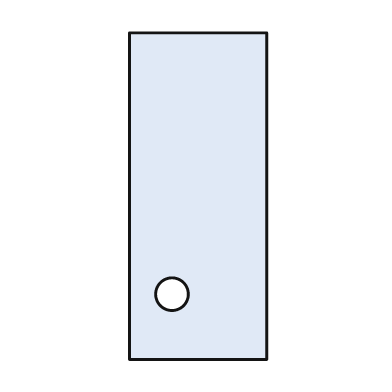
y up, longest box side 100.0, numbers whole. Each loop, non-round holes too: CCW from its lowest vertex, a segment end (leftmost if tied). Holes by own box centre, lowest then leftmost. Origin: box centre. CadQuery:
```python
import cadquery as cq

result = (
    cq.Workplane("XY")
    .moveTo(-21.0, -50.0)
    .lineTo(21.0, -50.0)
    .lineTo(21.0, 50.0)
    .lineTo(-21.0, 50.0)
    .close()
    .moveTo(-8.0, -30.0)
    .circle(5.0)
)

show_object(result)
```